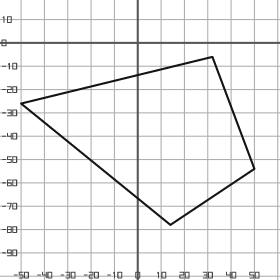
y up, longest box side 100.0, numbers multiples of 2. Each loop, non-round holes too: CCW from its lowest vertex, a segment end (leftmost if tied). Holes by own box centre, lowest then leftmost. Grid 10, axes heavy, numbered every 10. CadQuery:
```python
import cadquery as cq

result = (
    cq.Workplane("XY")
    .moveTo(14.0, -78.0)
    .lineTo(50.0, -54.0)
    .lineTo(32.0, -6.0)
    .lineTo(-50.0, -26.0)
    .close()
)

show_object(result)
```